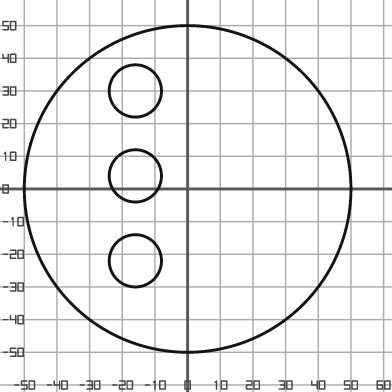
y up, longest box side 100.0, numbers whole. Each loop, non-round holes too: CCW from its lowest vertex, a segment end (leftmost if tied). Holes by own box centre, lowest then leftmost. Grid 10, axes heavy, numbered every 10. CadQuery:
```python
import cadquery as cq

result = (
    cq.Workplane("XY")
    .moveTo(0.0, 0.0)
    .circle(50.0)
    .moveTo(-16.0, -22.0)
    .circle(8.0)
    .moveTo(-16.0, 4.0)
    .circle(8.0)
    .moveTo(-16.0, 30.0)
    .circle(8.0)
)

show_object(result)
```